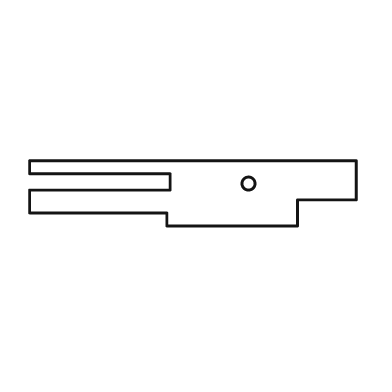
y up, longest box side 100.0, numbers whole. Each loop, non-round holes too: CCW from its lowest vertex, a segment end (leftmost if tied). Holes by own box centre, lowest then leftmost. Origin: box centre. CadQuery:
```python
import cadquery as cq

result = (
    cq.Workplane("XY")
    .moveTo(-8.0, -10.0)
    .lineTo(32.0, -10.0)
    .lineTo(32.0, -2.0)
    .lineTo(50.0, -2.0)
    .lineTo(50.0, 10.0)
    .lineTo(-50.0, 10.0)
    .lineTo(-50.0, 6.0)
    .lineTo(-7.0, 6.0)
    .lineTo(-7.0, 1.0)
    .lineTo(-50.0, 1.0)
    .lineTo(-50.0, -6.0)
    .lineTo(-8.0, -6.0)
    .close()
    .moveTo(17.0, 3.0)
    .circle(2.0)
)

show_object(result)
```